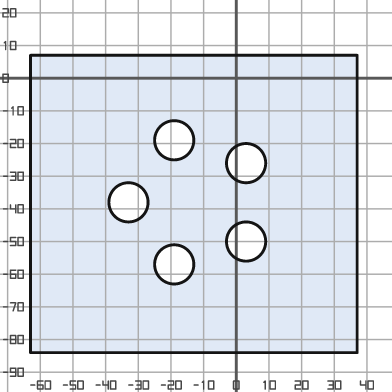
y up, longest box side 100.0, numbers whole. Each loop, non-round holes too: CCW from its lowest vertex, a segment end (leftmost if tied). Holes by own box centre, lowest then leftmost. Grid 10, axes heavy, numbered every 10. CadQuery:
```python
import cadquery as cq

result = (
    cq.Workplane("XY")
    .moveTo(-63.0, -84.0)
    .lineTo(37.0, -84.0)
    .lineTo(37.0, 7.0)
    .lineTo(-63.0, 7.0)
    .close()
    .moveTo(-19.0, -57.0)
    .circle(6.0)
    .moveTo(3.0, -50.0)
    .circle(6.0)
    .moveTo(-33.0, -38.0)
    .circle(6.0)
    .moveTo(3.0, -26.0)
    .circle(6.0)
    .moveTo(-19.0, -19.0)
    .circle(6.0)
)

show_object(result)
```